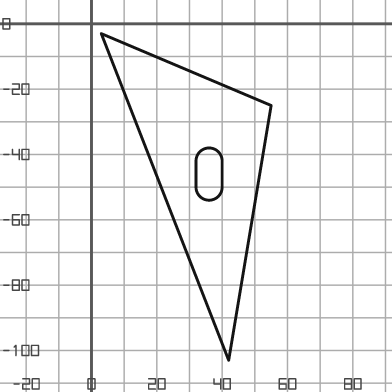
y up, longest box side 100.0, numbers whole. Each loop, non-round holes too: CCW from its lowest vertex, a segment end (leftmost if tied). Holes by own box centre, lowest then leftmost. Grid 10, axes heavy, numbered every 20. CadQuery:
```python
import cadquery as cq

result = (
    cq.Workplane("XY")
    .moveTo(42.0, -103.0)
    .lineTo(55.0, -25.0)
    .lineTo(3.0, -3.0)
    .close()
    .moveTo(32.0, -50.0)
    .threePointArc((36.0, -54.0), (40.0, -50.0))
    .lineTo(40.0, -42.0)
    .threePointArc((36.0, -38.0), (32.0, -42.0))
    .close()
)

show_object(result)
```